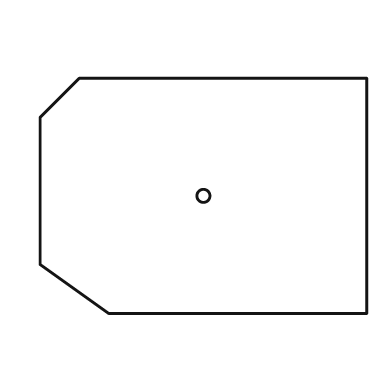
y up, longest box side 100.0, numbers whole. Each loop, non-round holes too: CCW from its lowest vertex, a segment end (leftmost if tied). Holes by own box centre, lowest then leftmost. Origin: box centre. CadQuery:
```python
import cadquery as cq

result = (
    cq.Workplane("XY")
    .moveTo(-29.0, -36.0)
    .lineTo(50.0, -36.0)
    .lineTo(50.0, 36.0)
    .lineTo(-38.0, 36.0)
    .lineTo(-50.0, 24.0)
    .lineTo(-50.0, -21.0)
    .close()
    .moveTo(0.0, 0.0)
    .circle(2.0)
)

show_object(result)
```